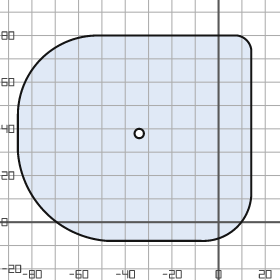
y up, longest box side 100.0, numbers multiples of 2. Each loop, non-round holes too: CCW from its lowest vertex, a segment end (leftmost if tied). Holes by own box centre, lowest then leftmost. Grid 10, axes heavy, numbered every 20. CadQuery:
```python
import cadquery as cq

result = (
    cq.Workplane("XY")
    .moveTo(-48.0, -8.0)
    .lineTo(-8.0, -8.0)
    .threePointArc((8.0, -2.0), (14.0, 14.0))
    .lineTo(14.0, 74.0)
    .threePointArc((12.0, 78.0), (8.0, 80.0))
    .lineTo(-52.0, 80.0)
    .threePointArc((-76.0, 70.0), (-86.0, 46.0))
    .lineTo(-86.0, 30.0)
    .threePointArc((-74.0, 4.0), (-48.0, -8.0))
    .close()
    .moveTo(-34.0, 38.0)
    .circle(2.0)
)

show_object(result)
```